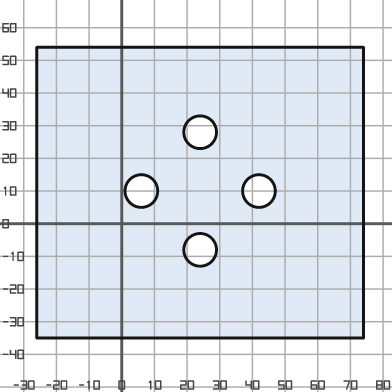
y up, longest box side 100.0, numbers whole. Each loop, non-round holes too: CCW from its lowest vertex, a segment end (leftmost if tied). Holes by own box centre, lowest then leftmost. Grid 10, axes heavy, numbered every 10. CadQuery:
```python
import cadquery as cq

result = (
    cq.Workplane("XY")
    .moveTo(-26.0, -35.0)
    .lineTo(74.0, -35.0)
    .lineTo(74.0, 54.0)
    .lineTo(-26.0, 54.0)
    .close()
    .moveTo(24.0, -8.0)
    .circle(5.0)
    .moveTo(6.0, 10.0)
    .circle(5.0)
    .moveTo(42.0, 10.0)
    .circle(5.0)
    .moveTo(24.0, 28.0)
    .circle(5.0)
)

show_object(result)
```